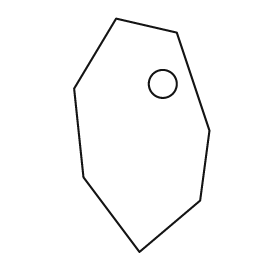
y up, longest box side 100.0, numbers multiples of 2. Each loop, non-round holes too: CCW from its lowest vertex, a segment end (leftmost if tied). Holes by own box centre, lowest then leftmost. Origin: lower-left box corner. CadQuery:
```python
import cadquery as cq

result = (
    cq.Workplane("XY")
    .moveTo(28.0, 0.0)
    .lineTo(54.0, 22.0)
    .lineTo(58.0, 52.0)
    .lineTo(44.0, 94.0)
    .lineTo(18.0, 100.0)
    .lineTo(0.0, 70.0)
    .lineTo(4.0, 32.0)
    .close()
    .moveTo(38.0, 72.0)
    .circle(6.0)
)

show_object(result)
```